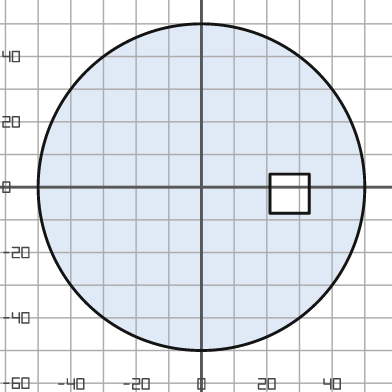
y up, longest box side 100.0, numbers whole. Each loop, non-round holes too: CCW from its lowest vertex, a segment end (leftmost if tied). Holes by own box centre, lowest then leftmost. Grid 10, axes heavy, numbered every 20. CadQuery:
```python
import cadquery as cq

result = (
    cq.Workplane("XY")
    .moveTo(0.0, 0.0)
    .circle(50.0)
    .moveTo(21.0, -8.0)
    .lineTo(33.0, -8.0)
    .lineTo(33.0, 4.0)
    .lineTo(21.0, 4.0)
    .close()
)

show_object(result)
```